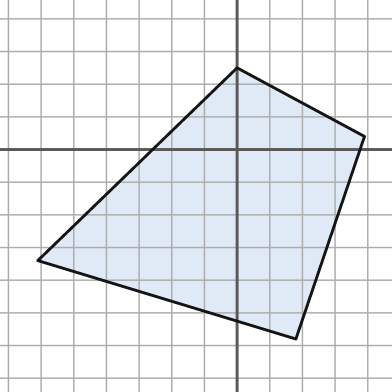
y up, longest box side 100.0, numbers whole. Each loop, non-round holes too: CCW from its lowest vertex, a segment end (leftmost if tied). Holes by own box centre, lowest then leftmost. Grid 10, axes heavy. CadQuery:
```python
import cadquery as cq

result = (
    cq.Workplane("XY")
    .moveTo(18.0, -58.0)
    .lineTo(39.0, 4.0)
    .lineTo(0.0, 25.0)
    .lineTo(-61.0, -34.0)
    .close()
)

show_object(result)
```